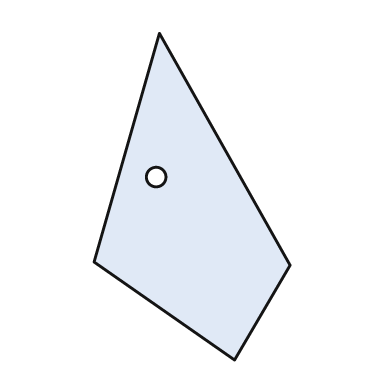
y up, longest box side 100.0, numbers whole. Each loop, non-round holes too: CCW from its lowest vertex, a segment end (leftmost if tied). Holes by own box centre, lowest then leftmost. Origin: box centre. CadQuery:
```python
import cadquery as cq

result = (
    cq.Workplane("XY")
    .moveTo(13.0, -50.0)
    .lineTo(30.0, -21.0)
    .lineTo(-10.0, 50.0)
    .lineTo(-30.0, -20.0)
    .close()
    .moveTo(-11.0, 6.0)
    .circle(3.0)
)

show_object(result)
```